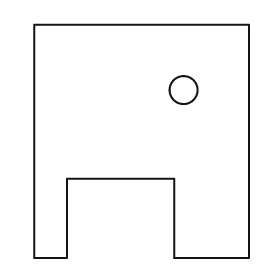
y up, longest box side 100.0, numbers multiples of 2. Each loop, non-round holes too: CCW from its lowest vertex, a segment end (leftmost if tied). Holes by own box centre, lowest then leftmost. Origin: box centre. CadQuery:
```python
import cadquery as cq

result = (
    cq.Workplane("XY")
    .moveTo(-46.0, -50.0)
    .lineTo(-32.0, -50.0)
    .lineTo(-32.0, -16.0)
    .lineTo(14.0, -16.0)
    .lineTo(14.0, -50.0)
    .lineTo(46.0, -50.0)
    .lineTo(46.0, 50.0)
    .lineTo(-46.0, 50.0)
    .close()
    .moveTo(18.0, 22.0)
    .circle(6.0)
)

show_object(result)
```